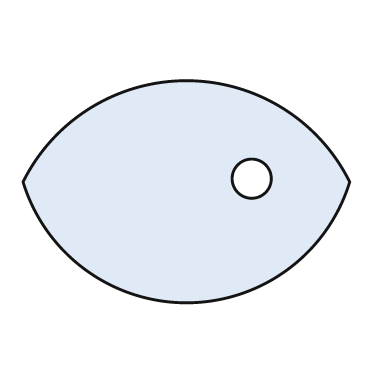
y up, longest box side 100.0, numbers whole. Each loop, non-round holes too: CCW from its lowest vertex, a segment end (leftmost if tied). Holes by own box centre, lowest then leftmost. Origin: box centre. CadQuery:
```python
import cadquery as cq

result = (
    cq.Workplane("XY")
    .moveTo(-50.0, 3.0)
    .threePointArc((0.0, -34.0), (50.0, 3.0))
    .threePointArc((0.0, 34.0), (-50.0, 3.0))
    .close()
    .moveTo(20.0, 4.0)
    .circle(6.0)
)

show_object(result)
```